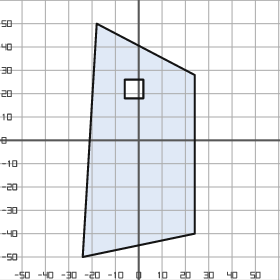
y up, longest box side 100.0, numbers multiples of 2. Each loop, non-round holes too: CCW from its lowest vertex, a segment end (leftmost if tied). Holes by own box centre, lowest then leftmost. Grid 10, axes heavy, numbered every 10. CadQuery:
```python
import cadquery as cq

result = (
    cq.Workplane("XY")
    .moveTo(-24.0, -50.0)
    .lineTo(24.0, -40.0)
    .lineTo(24.0, 28.0)
    .lineTo(-18.0, 50.0)
    .close()
    .moveTo(-6.0, 18.0)
    .lineTo(2.0, 18.0)
    .lineTo(2.0, 26.0)
    .lineTo(-6.0, 26.0)
    .close()
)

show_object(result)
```